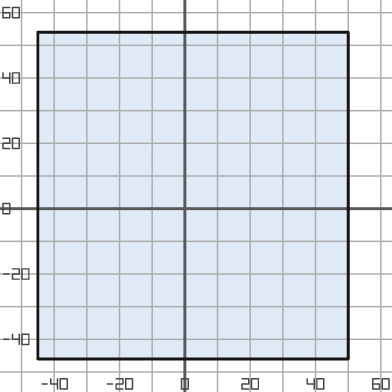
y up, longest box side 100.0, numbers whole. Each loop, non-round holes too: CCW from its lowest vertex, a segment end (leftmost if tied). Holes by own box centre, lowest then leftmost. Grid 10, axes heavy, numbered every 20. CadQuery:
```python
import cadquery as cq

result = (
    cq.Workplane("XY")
    .moveTo(-45.0, -46.0)
    .lineTo(50.0, -46.0)
    .lineTo(50.0, 54.0)
    .lineTo(-45.0, 54.0)
    .close()
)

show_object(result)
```